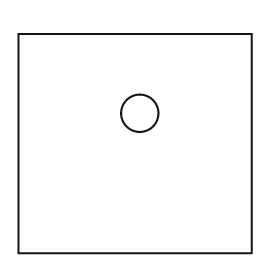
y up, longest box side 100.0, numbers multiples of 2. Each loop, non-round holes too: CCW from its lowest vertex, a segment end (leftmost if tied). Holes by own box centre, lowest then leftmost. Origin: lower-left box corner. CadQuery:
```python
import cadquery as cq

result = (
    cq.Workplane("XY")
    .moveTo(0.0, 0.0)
    .lineTo(100.0, 0.0)
    .lineTo(100.0, 94.0)
    .lineTo(0.0, 94.0)
    .close()
    .moveTo(52.0, 60.0)
    .circle(8.0)
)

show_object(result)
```